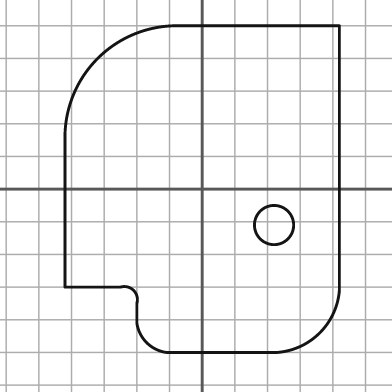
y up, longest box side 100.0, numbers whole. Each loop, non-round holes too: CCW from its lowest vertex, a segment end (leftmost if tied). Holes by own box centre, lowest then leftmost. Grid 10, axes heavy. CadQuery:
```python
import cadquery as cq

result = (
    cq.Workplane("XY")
    .moveTo(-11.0, -50.0)
    .lineTo(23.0, -50.0)
    .threePointArc((36.0, -44.0), (42.0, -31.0))
    .lineTo(42.0, 50.0)
    .lineTo(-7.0, 50.0)
    .threePointArc((-32.0, 40.0), (-42.0, 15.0))
    .lineTo(-42.0, -30.0)
    .lineTo(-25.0, -30.0)
    .threePointArc((-21.0, -31.0), (-20.0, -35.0))
    .lineTo(-20.0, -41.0)
    .threePointArc((-17.0, -47.0), (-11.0, -50.0))
    .close()
    .moveTo(22.0, -11.0)
    .circle(6.0)
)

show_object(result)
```